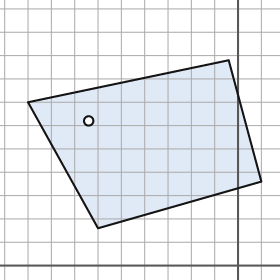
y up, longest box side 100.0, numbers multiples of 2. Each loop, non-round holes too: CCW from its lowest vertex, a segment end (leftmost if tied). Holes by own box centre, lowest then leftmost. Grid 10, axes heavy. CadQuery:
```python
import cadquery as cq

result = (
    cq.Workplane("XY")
    .moveTo(-60.0, 16.0)
    .lineTo(10.0, 36.0)
    .lineTo(-4.0, 88.0)
    .lineTo(-90.0, 70.0)
    .close()
    .moveTo(-64.0, 62.0)
    .circle(2.0)
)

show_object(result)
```